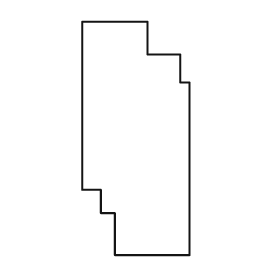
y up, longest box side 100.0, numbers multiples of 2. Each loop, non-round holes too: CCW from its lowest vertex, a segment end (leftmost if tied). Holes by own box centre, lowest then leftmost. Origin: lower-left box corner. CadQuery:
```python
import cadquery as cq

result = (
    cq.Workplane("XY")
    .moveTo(14.0, 0.0)
    .lineTo(46.0, 0.0)
    .lineTo(46.0, 74.0)
    .lineTo(42.0, 74.0)
    .lineTo(42.0, 86.0)
    .lineTo(28.0, 86.0)
    .lineTo(28.0, 100.0)
    .lineTo(0.0, 100.0)
    .lineTo(0.0, 28.0)
    .lineTo(8.0, 28.0)
    .lineTo(8.0, 18.0)
    .lineTo(14.0, 18.0)
    .close()
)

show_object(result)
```